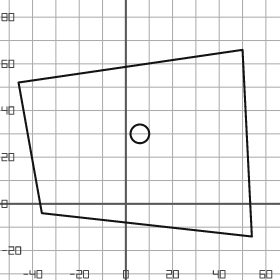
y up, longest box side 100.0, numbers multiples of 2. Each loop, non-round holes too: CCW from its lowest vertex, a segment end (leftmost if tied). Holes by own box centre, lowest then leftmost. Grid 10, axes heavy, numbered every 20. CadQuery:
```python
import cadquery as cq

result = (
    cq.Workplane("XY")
    .moveTo(54.0, -14.0)
    .lineTo(50.0, 66.0)
    .lineTo(-46.0, 52.0)
    .lineTo(-36.0, -4.0)
    .close()
    .moveTo(6.0, 30.0)
    .circle(4.0)
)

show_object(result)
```